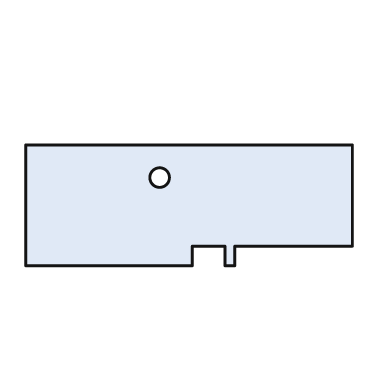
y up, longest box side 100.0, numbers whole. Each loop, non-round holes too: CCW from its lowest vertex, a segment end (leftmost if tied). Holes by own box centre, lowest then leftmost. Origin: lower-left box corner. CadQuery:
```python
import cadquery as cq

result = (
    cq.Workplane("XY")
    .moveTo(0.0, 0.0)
    .lineTo(51.0, 0.0)
    .lineTo(51.0, 6.0)
    .lineTo(61.0, 6.0)
    .lineTo(61.0, 0.0)
    .lineTo(64.0, 0.0)
    .lineTo(64.0, 6.0)
    .lineTo(100.0, 6.0)
    .lineTo(100.0, 37.0)
    .lineTo(0.0, 37.0)
    .close()
    .moveTo(41.0, 27.0)
    .circle(3.0)
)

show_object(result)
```